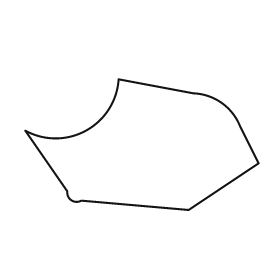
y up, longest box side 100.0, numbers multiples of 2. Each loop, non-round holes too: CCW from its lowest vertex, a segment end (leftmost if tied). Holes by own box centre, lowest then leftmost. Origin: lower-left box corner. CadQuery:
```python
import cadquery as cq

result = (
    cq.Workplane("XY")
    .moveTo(70.0, 0.0)
    .lineTo(100.0, 20.0)
    .lineTo(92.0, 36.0)
    .threePointArc((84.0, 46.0), (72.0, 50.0))
    .lineTo(40.0, 56.0)
    .threePointArc((26.0, 34.0), (0.0, 34.0))
    .lineTo(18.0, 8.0)
    .threePointArc((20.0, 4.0), (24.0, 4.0))
    .close()
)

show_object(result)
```